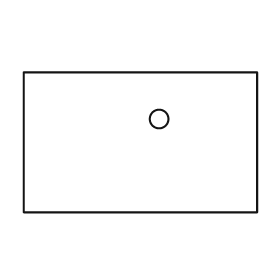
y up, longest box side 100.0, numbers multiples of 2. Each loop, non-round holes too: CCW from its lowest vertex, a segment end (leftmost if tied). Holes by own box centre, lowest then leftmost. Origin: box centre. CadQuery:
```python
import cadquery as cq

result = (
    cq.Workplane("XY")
    .moveTo(-50.0, -30.0)
    .lineTo(50.0, -30.0)
    .lineTo(50.0, 30.0)
    .lineTo(-50.0, 30.0)
    .close()
    .moveTo(8.0, 10.0)
    .circle(4.0)
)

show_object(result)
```